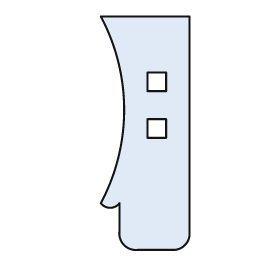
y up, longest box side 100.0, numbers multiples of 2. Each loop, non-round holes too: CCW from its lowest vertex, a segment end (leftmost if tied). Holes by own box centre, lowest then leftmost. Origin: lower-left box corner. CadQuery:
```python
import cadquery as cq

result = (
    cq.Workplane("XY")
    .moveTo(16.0, 0.0)
    .lineTo(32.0, 0.0)
    .threePointArc((36.0, 2.0), (38.0, 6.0))
    .lineTo(38.0, 100.0)
    .lineTo(0.0, 100.0)
    .threePointArc((10.0, 60.0), (0.0, 20.0))
    .threePointArc((4.0, 18.0), (8.0, 20.0))
    .lineTo(8.0, 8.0)
    .threePointArc((10.0, 2.0), (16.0, 0.0))
    .close()
    .moveTo(20.0, 48.0)
    .lineTo(28.0, 48.0)
    .lineTo(28.0, 56.0)
    .lineTo(20.0, 56.0)
    .close()
    .moveTo(20.0, 68.0)
    .lineTo(28.0, 68.0)
    .lineTo(28.0, 76.0)
    .lineTo(20.0, 76.0)
    .close()
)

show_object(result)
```